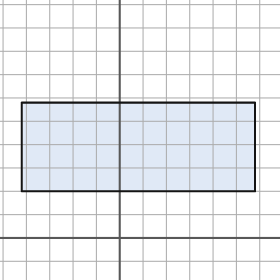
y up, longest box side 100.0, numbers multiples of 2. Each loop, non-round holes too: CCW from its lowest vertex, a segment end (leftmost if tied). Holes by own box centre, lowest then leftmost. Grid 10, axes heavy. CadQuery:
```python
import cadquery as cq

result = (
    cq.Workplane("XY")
    .moveTo(-42.0, 20.0)
    .lineTo(58.0, 20.0)
    .lineTo(58.0, 58.0)
    .lineTo(-42.0, 58.0)
    .close()
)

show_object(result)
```